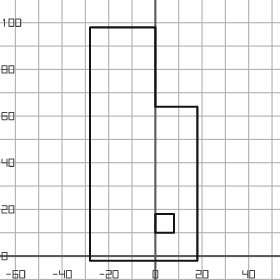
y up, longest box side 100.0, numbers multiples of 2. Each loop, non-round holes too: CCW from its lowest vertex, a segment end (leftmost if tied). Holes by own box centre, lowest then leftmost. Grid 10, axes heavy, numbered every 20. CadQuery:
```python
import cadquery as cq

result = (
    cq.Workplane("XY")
    .moveTo(-28.0, -2.0)
    .lineTo(18.0, -2.0)
    .lineTo(18.0, 64.0)
    .lineTo(0.0, 64.0)
    .lineTo(0.0, 98.0)
    .lineTo(-28.0, 98.0)
    .close()
    .moveTo(0.0, 10.0)
    .lineTo(8.0, 10.0)
    .lineTo(8.0, 18.0)
    .lineTo(0.0, 18.0)
    .close()
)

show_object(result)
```